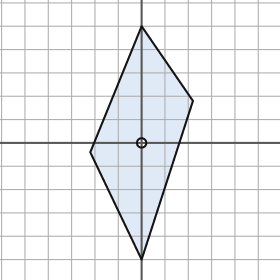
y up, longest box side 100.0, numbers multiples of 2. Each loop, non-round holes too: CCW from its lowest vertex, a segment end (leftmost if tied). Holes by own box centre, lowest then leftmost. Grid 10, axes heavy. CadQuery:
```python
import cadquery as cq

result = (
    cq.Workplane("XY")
    .moveTo(0.0, -50.0)
    .lineTo(22.0, 18.0)
    .lineTo(0.0, 50.0)
    .lineTo(-22.0, -4.0)
    .close()
    .moveTo(0.0, 0.0)
    .circle(2.0)
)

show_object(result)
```